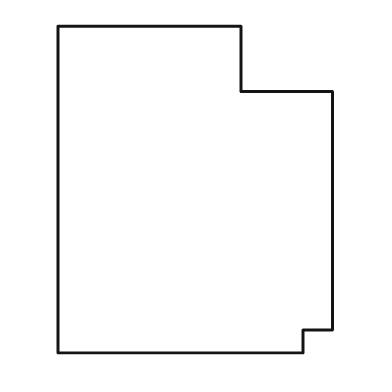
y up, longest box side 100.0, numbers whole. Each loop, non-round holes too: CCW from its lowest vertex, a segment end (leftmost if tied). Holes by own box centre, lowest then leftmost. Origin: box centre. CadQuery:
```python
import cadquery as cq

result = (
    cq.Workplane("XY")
    .moveTo(-42.0, -50.0)
    .lineTo(33.0, -50.0)
    .lineTo(33.0, -43.0)
    .lineTo(42.0, -43.0)
    .lineTo(42.0, 30.0)
    .lineTo(14.0, 30.0)
    .lineTo(14.0, 50.0)
    .lineTo(-42.0, 50.0)
    .close()
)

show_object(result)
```